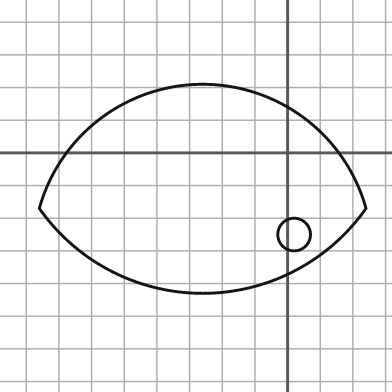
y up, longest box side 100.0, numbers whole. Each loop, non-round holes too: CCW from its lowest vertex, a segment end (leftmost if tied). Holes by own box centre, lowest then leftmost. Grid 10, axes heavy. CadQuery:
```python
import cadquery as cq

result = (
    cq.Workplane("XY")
    .moveTo(-76.0, -17.0)
    .threePointArc((-26.0, -43.0), (24.0, -17.0))
    .threePointArc((-26.0, 21.0), (-76.0, -17.0))
    .close()
    .moveTo(2.0, -25.0)
    .circle(5.0)
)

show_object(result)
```